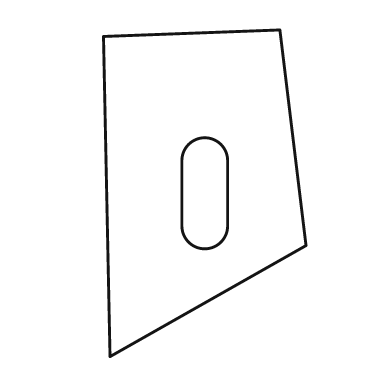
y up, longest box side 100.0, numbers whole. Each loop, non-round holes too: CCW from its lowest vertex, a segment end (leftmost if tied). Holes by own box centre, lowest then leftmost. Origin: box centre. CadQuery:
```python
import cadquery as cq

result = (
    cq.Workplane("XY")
    .moveTo(-29.0, -50.0)
    .lineTo(31.0, -16.0)
    .lineTo(23.0, 50.0)
    .lineTo(-31.0, 48.0)
    .close()
    .moveTo(-7.0, -10.0)
    .threePointArc((0.0, -17.0), (7.0, -10.0))
    .lineTo(7.0, 10.0)
    .threePointArc((0.0, 17.0), (-7.0, 10.0))
    .close()
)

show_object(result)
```